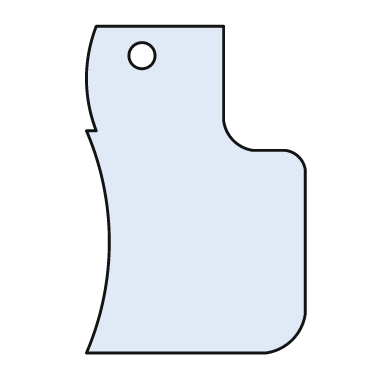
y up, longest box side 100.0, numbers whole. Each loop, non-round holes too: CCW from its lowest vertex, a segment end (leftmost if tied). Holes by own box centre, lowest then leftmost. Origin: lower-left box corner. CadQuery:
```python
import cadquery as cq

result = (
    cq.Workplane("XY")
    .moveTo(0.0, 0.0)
    .lineTo(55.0, 0.0)
    .threePointArc((63.0, 4.0), (67.0, 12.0))
    .lineTo(67.0, 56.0)
    .threePointArc((65.0, 60.0), (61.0, 62.0))
    .lineTo(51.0, 62.0)
    .threePointArc((45.0, 65.0), (42.0, 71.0))
    .lineTo(42.0, 100.0)
    .lineTo(3.0, 100.0)
    .threePointArc((0.0, 84.0), (3.0, 68.0))
    .lineTo(0.0, 68.0)
    .threePointArc((7.0, 34.0), (0.0, 0.0))
    .close()
    .moveTo(17.0, 91.0)
    .circle(4.0)
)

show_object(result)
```